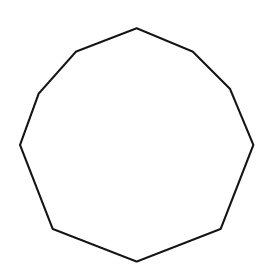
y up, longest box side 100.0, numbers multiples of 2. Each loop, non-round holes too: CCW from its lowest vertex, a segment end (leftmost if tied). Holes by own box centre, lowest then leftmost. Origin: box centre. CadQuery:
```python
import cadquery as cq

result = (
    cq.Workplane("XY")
    .moveTo(0.0, -50.0)
    .lineTo(36.0, -36.0)
    .lineTo(50.0, 0.0)
    .lineTo(40.0, 24.0)
    .lineTo(24.0, 40.0)
    .lineTo(0.0, 50.0)
    .lineTo(-26.0, 40.0)
    .lineTo(-42.0, 22.0)
    .lineTo(-50.0, 0.0)
    .lineTo(-36.0, -36.0)
    .close()
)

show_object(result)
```